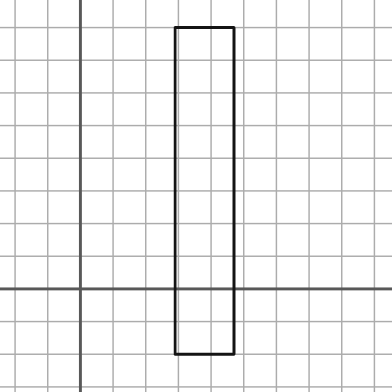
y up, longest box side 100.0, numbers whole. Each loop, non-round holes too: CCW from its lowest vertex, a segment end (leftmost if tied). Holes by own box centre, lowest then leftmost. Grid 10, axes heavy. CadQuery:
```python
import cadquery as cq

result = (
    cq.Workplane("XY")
    .moveTo(29.0, -20.0)
    .lineTo(47.0, -20.0)
    .lineTo(47.0, 80.0)
    .lineTo(29.0, 80.0)
    .close()
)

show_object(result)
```